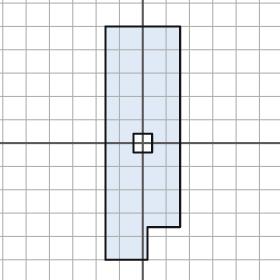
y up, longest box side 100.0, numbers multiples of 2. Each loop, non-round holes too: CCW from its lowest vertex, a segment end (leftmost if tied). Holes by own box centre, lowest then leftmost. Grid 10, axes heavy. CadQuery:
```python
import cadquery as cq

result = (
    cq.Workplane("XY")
    .moveTo(-16.0, -50.0)
    .lineTo(2.0, -50.0)
    .lineTo(2.0, -36.0)
    .lineTo(16.0, -36.0)
    .lineTo(16.0, 50.0)
    .lineTo(-16.0, 50.0)
    .close()
    .moveTo(-4.0, -4.0)
    .lineTo(4.0, -4.0)
    .lineTo(4.0, 4.0)
    .lineTo(-4.0, 4.0)
    .close()
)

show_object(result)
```